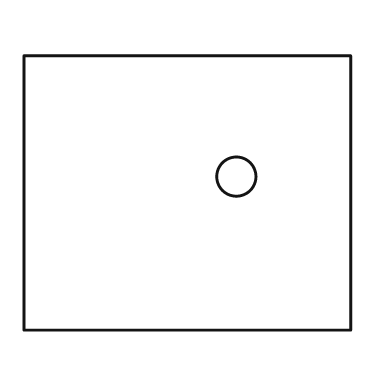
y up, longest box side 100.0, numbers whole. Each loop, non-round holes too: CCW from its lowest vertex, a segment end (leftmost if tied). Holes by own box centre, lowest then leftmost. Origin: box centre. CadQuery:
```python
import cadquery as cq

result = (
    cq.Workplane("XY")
    .moveTo(-50.0, -42.0)
    .lineTo(50.0, -42.0)
    .lineTo(50.0, 42.0)
    .lineTo(-50.0, 42.0)
    .close()
    .moveTo(15.0, 5.0)
    .circle(6.0)
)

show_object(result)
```